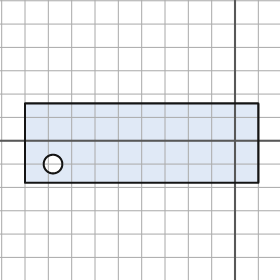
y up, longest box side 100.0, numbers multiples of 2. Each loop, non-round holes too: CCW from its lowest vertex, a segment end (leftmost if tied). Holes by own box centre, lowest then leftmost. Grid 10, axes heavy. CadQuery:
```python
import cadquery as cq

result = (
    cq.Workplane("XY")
    .moveTo(-90.0, -18.0)
    .lineTo(10.0, -18.0)
    .lineTo(10.0, 16.0)
    .lineTo(-90.0, 16.0)
    .close()
    .moveTo(-78.0, -10.0)
    .circle(4.0)
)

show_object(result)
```